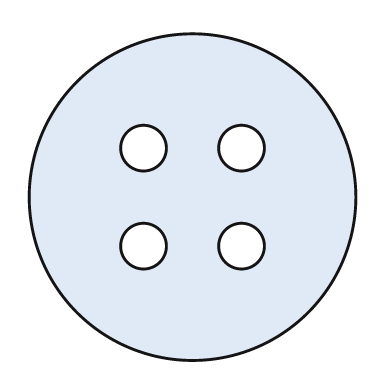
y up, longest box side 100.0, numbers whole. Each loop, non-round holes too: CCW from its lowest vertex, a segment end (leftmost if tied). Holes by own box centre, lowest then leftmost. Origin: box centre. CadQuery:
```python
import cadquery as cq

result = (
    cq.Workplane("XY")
    .moveTo(0.0, 0.0)
    .circle(50.0)
    .moveTo(-15.0, -15.0)
    .circle(7.0)
    .moveTo(15.0, -15.0)
    .circle(7.0)
    .moveTo(-15.0, 15.0)
    .circle(7.0)
    .moveTo(15.0, 15.0)
    .circle(7.0)
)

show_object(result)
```